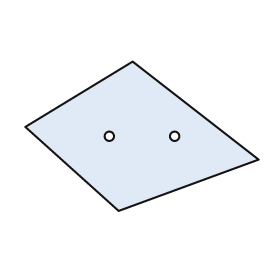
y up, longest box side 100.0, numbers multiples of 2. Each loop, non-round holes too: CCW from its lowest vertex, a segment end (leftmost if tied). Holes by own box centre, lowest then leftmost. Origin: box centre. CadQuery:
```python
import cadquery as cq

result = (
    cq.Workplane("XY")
    .moveTo(-10.0, -32.0)
    .lineTo(50.0, -10.0)
    .lineTo(-4.0, 32.0)
    .lineTo(-50.0, 4.0)
    .close()
    .moveTo(-14.0, 0.0)
    .circle(2.0)
    .moveTo(14.0, 0.0)
    .circle(2.0)
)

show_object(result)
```